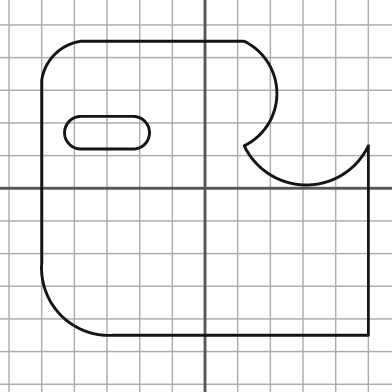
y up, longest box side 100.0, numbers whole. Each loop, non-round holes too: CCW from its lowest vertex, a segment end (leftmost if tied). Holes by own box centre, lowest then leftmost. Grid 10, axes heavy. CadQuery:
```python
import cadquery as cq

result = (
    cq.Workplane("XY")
    .moveTo(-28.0, -45.0)
    .lineTo(50.0, -45.0)
    .lineTo(50.0, 13.0)
    .threePointArc((31.0, 1.0), (12.0, 13.0))
    .threePointArc((22.0, 29.0), (12.0, 45.0))
    .lineTo(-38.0, 45.0)
    .threePointArc((-46.0, 41.0), (-50.0, 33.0))
    .lineTo(-50.0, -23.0)
    .threePointArc((-44.0, -39.0), (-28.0, -45.0))
    .close()
    .moveTo(-38.0, 12.0)
    .lineTo(-22.0, 12.0)
    .threePointArc((-17.0, 17.0), (-22.0, 22.0))
    .lineTo(-38.0, 22.0)
    .threePointArc((-43.0, 17.0), (-38.0, 12.0))
    .close()
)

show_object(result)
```